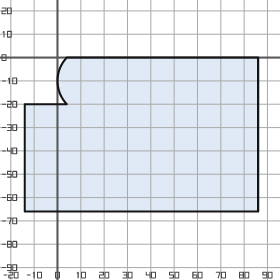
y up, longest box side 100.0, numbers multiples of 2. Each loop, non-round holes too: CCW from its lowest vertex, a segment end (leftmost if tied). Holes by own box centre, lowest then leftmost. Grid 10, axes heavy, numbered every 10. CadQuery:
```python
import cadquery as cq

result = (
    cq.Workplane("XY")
    .moveTo(-14.0, -66.0)
    .lineTo(86.0, -66.0)
    .lineTo(86.0, 0.0)
    .lineTo(4.0, 0.0)
    .threePointArc((0.0, -10.0), (4.0, -20.0))
    .lineTo(-14.0, -20.0)
    .close()
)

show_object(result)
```